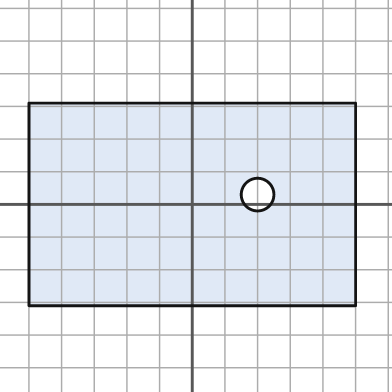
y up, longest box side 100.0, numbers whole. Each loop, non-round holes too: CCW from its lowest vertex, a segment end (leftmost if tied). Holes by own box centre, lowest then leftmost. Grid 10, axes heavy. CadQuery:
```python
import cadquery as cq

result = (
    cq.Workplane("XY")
    .moveTo(-50.0, -31.0)
    .lineTo(50.0, -31.0)
    .lineTo(50.0, 31.0)
    .lineTo(-50.0, 31.0)
    .close()
    .moveTo(20.0, 3.0)
    .circle(5.0)
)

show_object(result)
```